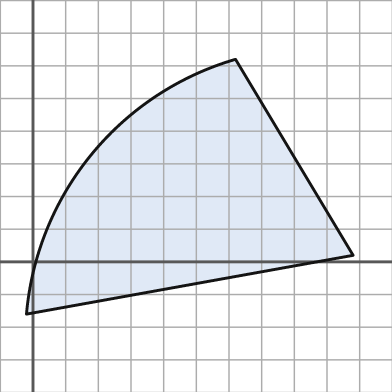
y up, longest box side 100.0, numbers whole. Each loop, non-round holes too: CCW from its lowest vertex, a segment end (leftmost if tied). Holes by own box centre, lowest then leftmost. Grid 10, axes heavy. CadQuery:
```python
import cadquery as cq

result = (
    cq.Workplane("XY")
    .moveTo(-2.0, -16.0)
    .lineTo(98.0, 2.0)
    .lineTo(62.0, 62.0)
    .threePointArc((18.0, 33.0), (-2.0, -16.0))
    .close()
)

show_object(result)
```